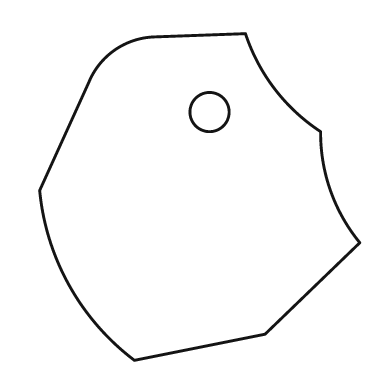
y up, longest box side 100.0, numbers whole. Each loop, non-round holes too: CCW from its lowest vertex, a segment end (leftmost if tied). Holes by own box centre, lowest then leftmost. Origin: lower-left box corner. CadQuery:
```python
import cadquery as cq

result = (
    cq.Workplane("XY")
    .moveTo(29.0, 0.0)
    .lineTo(69.0, 8.0)
    .lineTo(98.0, 36.0)
    .threePointArc((89.0, 52.0), (86.0, 70.0))
    .threePointArc((72.0, 83.0), (63.0, 100.0))
    .lineTo(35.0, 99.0)
    .threePointArc((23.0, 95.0), (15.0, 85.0))
    .lineTo(0.0, 52.0)
    .threePointArc((9.0, 23.0), (29.0, 0.0))
    .close()
    .moveTo(52.0, 76.0)
    .circle(6.0)
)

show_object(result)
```